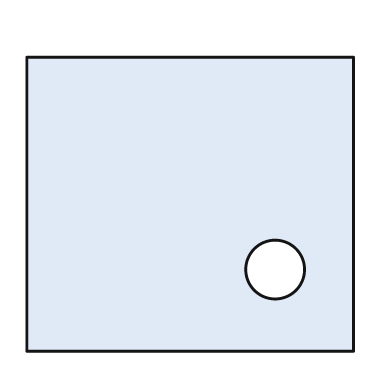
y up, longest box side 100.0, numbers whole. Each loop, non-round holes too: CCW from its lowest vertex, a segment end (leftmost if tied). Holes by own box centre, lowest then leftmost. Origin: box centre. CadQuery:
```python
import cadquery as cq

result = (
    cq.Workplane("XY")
    .moveTo(-50.0, -45.0)
    .lineTo(50.0, -45.0)
    .lineTo(50.0, 45.0)
    .lineTo(-50.0, 45.0)
    .close()
    .moveTo(26.0, -20.0)
    .circle(9.0)
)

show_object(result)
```